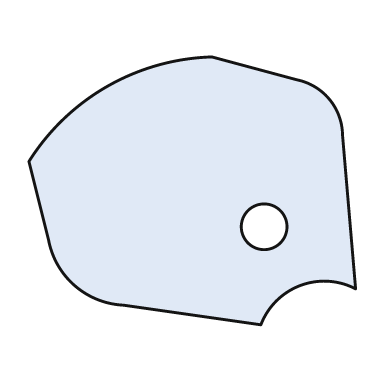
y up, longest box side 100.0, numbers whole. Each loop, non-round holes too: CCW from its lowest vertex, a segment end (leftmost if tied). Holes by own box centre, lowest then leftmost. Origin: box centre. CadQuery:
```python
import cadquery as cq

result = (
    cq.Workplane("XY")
    .moveTo(21.0, -41.0)
    .threePointArc((33.0, -29.0), (50.0, -30.0))
    .lineTo(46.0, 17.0)
    .threePointArc((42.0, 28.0), (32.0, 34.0))
    .lineTo(6.0, 41.0)
    .threePointArc((-26.0, 32.0), (-50.0, 9.0))
    .lineTo(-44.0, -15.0)
    .threePointArc((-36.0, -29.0), (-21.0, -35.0))
    .close()
    .moveTo(22.0, -11.0)
    .circle(7.0)
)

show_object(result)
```